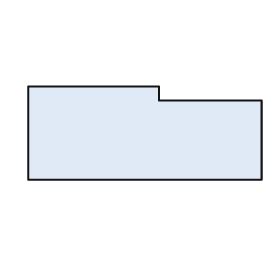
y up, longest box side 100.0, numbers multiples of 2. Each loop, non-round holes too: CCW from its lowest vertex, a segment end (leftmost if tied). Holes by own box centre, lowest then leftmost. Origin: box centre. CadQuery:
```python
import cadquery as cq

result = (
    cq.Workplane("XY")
    .moveTo(-50.0, -20.0)
    .lineTo(50.0, -20.0)
    .lineTo(50.0, 14.0)
    .lineTo(6.0, 14.0)
    .lineTo(6.0, 20.0)
    .lineTo(-50.0, 20.0)
    .close()
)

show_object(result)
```